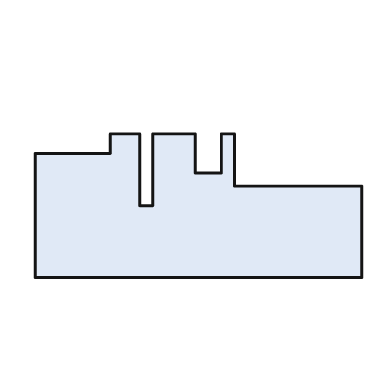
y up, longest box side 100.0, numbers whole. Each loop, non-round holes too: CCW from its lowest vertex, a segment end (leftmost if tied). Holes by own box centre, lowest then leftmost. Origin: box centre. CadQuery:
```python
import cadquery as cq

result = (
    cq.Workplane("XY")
    .moveTo(-50.0, -22.0)
    .lineTo(50.0, -22.0)
    .lineTo(50.0, 6.0)
    .lineTo(11.0, 6.0)
    .lineTo(11.0, 22.0)
    .lineTo(7.0, 22.0)
    .lineTo(7.0, 10.0)
    .lineTo(-1.0, 10.0)
    .lineTo(-1.0, 22.0)
    .lineTo(-14.0, 22.0)
    .lineTo(-14.0, 0.0)
    .lineTo(-18.0, 0.0)
    .lineTo(-18.0, 22.0)
    .lineTo(-27.0, 22.0)
    .lineTo(-27.0, 16.0)
    .lineTo(-50.0, 16.0)
    .close()
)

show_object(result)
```